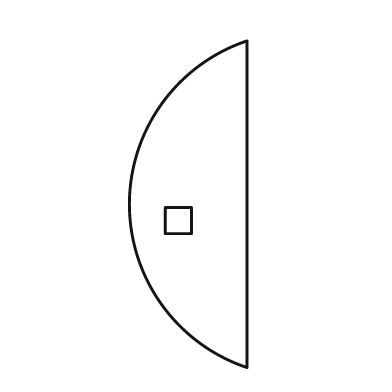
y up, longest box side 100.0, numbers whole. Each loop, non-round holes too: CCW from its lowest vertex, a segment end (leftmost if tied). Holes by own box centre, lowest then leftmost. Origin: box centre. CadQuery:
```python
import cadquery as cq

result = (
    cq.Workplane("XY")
    .moveTo(18.0, -50.0)
    .lineTo(18.0, 50.0)
    .threePointArc((-18.0, 0.0), (18.0, -50.0))
    .close()
    .moveTo(-7.0, -9.0)
    .lineTo(1.0, -9.0)
    .lineTo(1.0, -1.0)
    .lineTo(-7.0, -1.0)
    .close()
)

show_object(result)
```